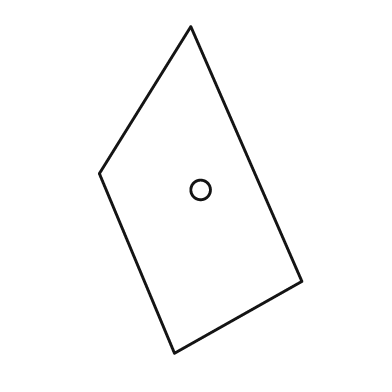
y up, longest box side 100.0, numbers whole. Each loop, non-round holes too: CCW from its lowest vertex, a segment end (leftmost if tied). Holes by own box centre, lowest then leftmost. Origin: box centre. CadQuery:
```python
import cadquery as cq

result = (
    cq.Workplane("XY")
    .moveTo(-8.0, -50.0)
    .lineTo(31.0, -28.0)
    .lineTo(-3.0, 50.0)
    .lineTo(-31.0, 5.0)
    .close()
    .moveTo(0.0, 0.0)
    .circle(3.0)
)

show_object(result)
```